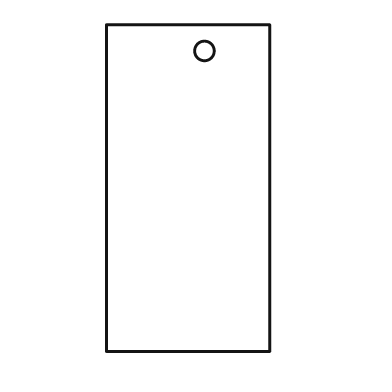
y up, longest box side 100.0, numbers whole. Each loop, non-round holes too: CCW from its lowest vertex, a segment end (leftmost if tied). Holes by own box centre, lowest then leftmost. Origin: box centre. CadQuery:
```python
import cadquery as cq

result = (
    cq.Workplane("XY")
    .moveTo(-25.0, -50.0)
    .lineTo(25.0, -50.0)
    .lineTo(25.0, 50.0)
    .lineTo(-25.0, 50.0)
    .close()
    .moveTo(5.0, 42.0)
    .circle(3.0)
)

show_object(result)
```